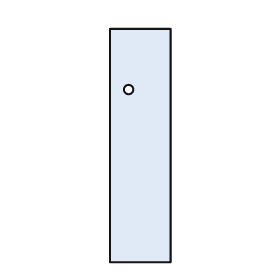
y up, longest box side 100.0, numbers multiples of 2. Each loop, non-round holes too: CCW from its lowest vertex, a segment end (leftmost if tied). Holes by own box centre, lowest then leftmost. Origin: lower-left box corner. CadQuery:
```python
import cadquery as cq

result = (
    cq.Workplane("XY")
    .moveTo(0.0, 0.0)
    .lineTo(26.0, 0.0)
    .lineTo(26.0, 100.0)
    .lineTo(0.0, 100.0)
    .close()
    .moveTo(8.0, 74.0)
    .circle(2.0)
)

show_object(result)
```